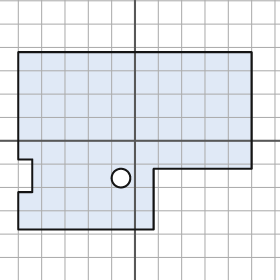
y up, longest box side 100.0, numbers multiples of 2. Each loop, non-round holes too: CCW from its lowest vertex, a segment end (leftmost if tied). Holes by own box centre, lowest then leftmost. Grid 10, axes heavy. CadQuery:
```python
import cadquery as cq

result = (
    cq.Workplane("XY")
    .moveTo(-50.0, -38.0)
    .lineTo(8.0, -38.0)
    .lineTo(8.0, -12.0)
    .lineTo(50.0, -12.0)
    .lineTo(50.0, 38.0)
    .lineTo(-50.0, 38.0)
    .lineTo(-50.0, -8.0)
    .lineTo(-44.0, -8.0)
    .lineTo(-44.0, -22.0)
    .lineTo(-50.0, -22.0)
    .close()
    .moveTo(-6.0, -16.0)
    .circle(4.0)
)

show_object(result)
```